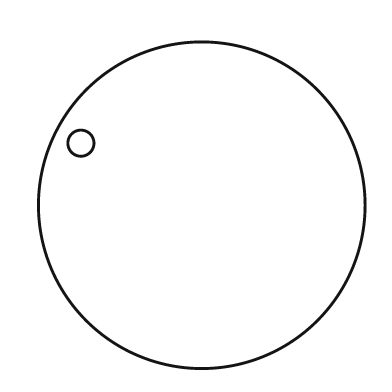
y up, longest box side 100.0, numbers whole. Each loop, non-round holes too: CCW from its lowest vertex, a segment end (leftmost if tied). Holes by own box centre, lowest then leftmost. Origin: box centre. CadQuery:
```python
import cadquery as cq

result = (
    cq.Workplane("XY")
    .moveTo(0.0, 0.0)
    .circle(50.0)
    .moveTo(-37.0, 19.0)
    .circle(4.0)
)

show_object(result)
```